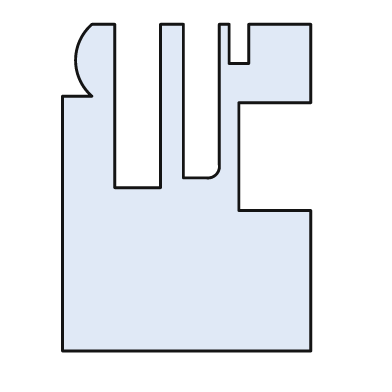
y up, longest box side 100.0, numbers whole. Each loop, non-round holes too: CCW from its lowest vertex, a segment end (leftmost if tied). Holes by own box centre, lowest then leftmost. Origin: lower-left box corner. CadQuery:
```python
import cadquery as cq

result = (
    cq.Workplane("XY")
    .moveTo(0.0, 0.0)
    .lineTo(76.0, 0.0)
    .lineTo(76.0, 43.0)
    .lineTo(54.0, 43.0)
    .lineTo(54.0, 76.0)
    .lineTo(76.0, 76.0)
    .lineTo(76.0, 100.0)
    .lineTo(57.0, 100.0)
    .lineTo(57.0, 88.0)
    .lineTo(51.0, 88.0)
    .lineTo(51.0, 100.0)
    .lineTo(48.0, 100.0)
    .lineTo(48.0, 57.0)
    .threePointArc((47.0, 54.0), (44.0, 53.0))
    .lineTo(37.0, 53.0)
    .lineTo(37.0, 100.0)
    .lineTo(30.0, 100.0)
    .lineTo(30.0, 50.0)
    .lineTo(16.0, 50.0)
    .lineTo(16.0, 100.0)
    .lineTo(9.0, 100.0)
    .threePointArc((4.0, 89.0), (9.0, 78.0))
    .lineTo(0.0, 78.0)
    .close()
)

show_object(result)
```